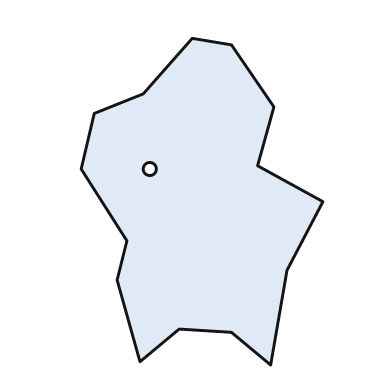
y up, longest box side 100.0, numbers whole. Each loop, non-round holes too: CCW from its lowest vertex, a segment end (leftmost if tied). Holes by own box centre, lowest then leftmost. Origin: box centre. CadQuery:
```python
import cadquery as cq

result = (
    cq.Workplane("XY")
    .moveTo(21.0, -50.0)
    .lineTo(26.0, -21.0)
    .lineTo(37.0, 0.0)
    .lineTo(17.0, 11.0)
    .lineTo(22.0, 29.0)
    .lineTo(9.0, 48.0)
    .lineTo(-3.0, 50.0)
    .lineTo(-18.0, 33.0)
    .lineTo(-33.0, 27.0)
    .lineTo(-37.0, 10.0)
    .lineTo(-23.0, -12.0)
    .lineTo(-26.0, -24.0)
    .lineTo(-19.0, -49.0)
    .lineTo(-7.0, -39.0)
    .lineTo(9.0, -40.0)
    .close()
    .moveTo(-16.0, 10.0)
    .circle(2.0)
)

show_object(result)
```